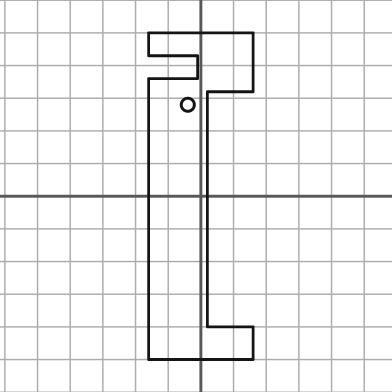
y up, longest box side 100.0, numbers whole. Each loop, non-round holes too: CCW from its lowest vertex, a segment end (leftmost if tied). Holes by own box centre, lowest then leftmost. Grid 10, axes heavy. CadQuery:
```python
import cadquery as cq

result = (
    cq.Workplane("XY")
    .moveTo(-16.0, -50.0)
    .lineTo(16.0, -50.0)
    .lineTo(16.0, -40.0)
    .lineTo(2.0, -40.0)
    .lineTo(2.0, 32.0)
    .lineTo(16.0, 32.0)
    .lineTo(16.0, 50.0)
    .lineTo(-16.0, 50.0)
    .lineTo(-16.0, 43.0)
    .lineTo(-1.0, 43.0)
    .lineTo(-1.0, 36.0)
    .lineTo(-16.0, 36.0)
    .close()
    .moveTo(-4.0, 28.0)
    .circle(2.0)
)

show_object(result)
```